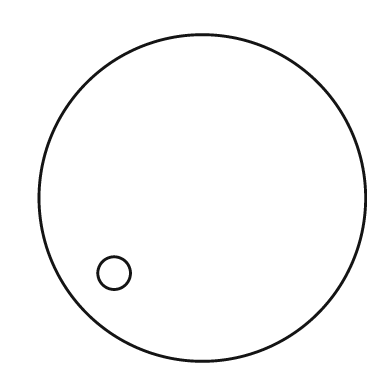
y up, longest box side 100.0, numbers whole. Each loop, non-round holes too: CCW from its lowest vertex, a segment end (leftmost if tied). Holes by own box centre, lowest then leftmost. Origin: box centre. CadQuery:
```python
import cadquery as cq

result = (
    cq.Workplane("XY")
    .moveTo(0.0, 0.0)
    .circle(50.0)
    .moveTo(-27.0, -23.0)
    .circle(5.0)
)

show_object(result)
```